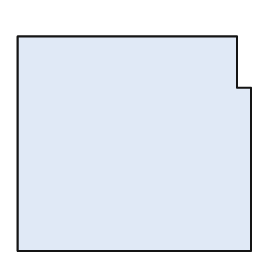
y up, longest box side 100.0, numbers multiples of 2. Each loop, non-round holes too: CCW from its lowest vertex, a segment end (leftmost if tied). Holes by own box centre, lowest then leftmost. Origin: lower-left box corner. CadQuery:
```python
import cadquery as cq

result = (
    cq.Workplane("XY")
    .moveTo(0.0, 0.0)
    .lineTo(100.0, 0.0)
    .lineTo(100.0, 70.0)
    .lineTo(94.0, 70.0)
    .lineTo(94.0, 92.0)
    .lineTo(0.0, 92.0)
    .close()
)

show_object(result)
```